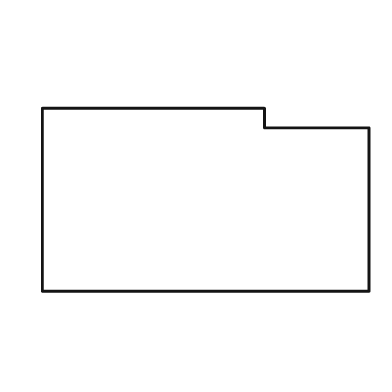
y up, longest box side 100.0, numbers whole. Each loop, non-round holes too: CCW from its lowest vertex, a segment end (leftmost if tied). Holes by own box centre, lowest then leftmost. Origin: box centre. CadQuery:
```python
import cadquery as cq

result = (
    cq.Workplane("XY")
    .moveTo(-50.0, -28.0)
    .lineTo(50.0, -28.0)
    .lineTo(50.0, 22.0)
    .lineTo(18.0, 22.0)
    .lineTo(18.0, 28.0)
    .lineTo(-50.0, 28.0)
    .close()
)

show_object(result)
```